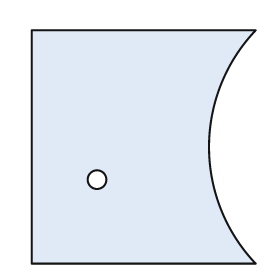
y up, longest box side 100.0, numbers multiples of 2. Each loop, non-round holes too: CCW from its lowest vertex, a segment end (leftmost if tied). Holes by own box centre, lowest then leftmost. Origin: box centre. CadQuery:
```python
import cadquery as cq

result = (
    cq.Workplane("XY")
    .moveTo(-48.0, -50.0)
    .lineTo(48.0, -50.0)
    .threePointArc((28.0, 0.0), (48.0, 50.0))
    .lineTo(-48.0, 50.0)
    .close()
    .moveTo(-20.0, -14.0)
    .circle(4.0)
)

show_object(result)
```